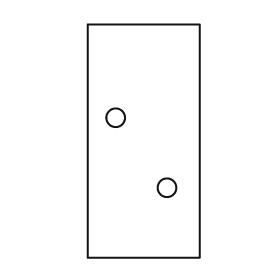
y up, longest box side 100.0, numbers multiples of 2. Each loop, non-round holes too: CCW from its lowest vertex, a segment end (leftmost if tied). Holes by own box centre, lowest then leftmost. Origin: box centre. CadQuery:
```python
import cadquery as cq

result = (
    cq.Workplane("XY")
    .moveTo(-24.0, -50.0)
    .lineTo(24.0, -50.0)
    .lineTo(24.0, 50.0)
    .lineTo(-24.0, 50.0)
    .close()
    .moveTo(10.0, -20.0)
    .circle(4.0)
    .moveTo(-12.0, 10.0)
    .circle(4.0)
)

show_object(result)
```